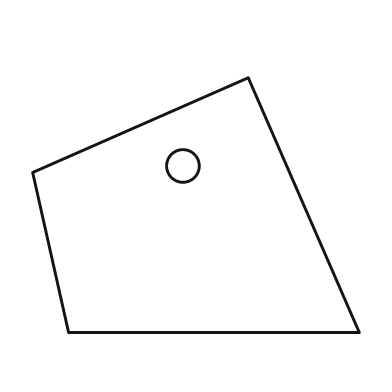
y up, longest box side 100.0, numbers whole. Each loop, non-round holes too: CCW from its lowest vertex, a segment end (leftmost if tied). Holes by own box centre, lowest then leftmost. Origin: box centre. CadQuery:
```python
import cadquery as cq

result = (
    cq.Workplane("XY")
    .moveTo(-39.0, -39.0)
    .lineTo(50.0, -39.0)
    .lineTo(16.0, 39.0)
    .lineTo(-50.0, 10.0)
    .close()
    .moveTo(-4.0, 12.0)
    .circle(5.0)
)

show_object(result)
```